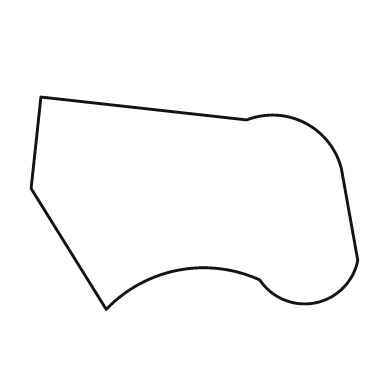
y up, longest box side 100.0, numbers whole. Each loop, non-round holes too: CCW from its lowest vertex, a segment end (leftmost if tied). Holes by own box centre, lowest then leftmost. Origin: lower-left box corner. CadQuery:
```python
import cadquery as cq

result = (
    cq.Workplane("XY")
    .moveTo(23.0, 0.0)
    .threePointArc((45.0, 12.0), (70.0, 9.0))
    .threePointArc((87.0, 2.0), (100.0, 15.0))
    .lineTo(95.0, 43.0)
    .threePointArc((84.0, 57.0), (66.0, 58.0))
    .lineTo(3.0, 65.0)
    .lineTo(0.0, 37.0)
    .close()
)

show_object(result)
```